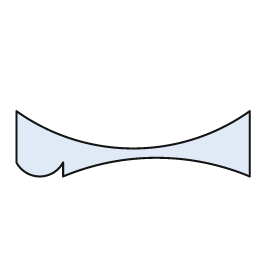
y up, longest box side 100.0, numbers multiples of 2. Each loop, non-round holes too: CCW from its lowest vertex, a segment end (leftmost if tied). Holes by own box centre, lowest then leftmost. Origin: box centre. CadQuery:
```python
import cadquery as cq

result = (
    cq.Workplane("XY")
    .moveTo(-30.0, -14.0)
    .threePointArc((10.0, -6.0), (50.0, -14.0))
    .lineTo(50.0, 14.0)
    .threePointArc((0.0, -2.0), (-50.0, 14.0))
    .lineTo(-50.0, -8.0)
    .threePointArc((-40.0, -14.0), (-30.0, -8.0))
    .close()
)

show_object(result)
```